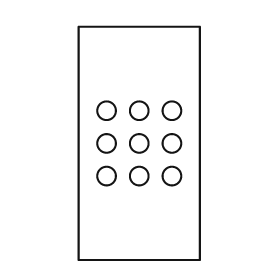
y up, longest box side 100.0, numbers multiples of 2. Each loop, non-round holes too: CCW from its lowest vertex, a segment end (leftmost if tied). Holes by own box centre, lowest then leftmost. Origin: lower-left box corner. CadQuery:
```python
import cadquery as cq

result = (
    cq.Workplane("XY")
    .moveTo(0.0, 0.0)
    .lineTo(52.0, 0.0)
    .lineTo(52.0, 100.0)
    .lineTo(0.0, 100.0)
    .close()
    .moveTo(12.0, 36.0)
    .circle(4.0)
    .moveTo(26.0, 36.0)
    .circle(4.0)
    .moveTo(40.0, 36.0)
    .circle(4.0)
    .moveTo(12.0, 50.0)
    .circle(4.0)
    .moveTo(26.0, 50.0)
    .circle(4.0)
    .moveTo(40.0, 50.0)
    .circle(4.0)
    .moveTo(12.0, 64.0)
    .circle(4.0)
    .moveTo(26.0, 64.0)
    .circle(4.0)
    .moveTo(40.0, 64.0)
    .circle(4.0)
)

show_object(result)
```